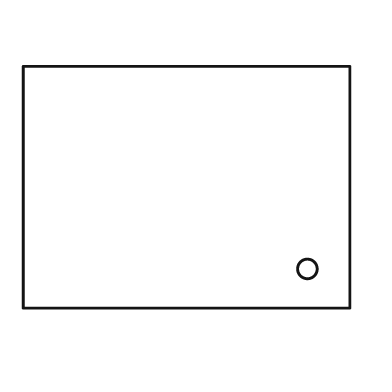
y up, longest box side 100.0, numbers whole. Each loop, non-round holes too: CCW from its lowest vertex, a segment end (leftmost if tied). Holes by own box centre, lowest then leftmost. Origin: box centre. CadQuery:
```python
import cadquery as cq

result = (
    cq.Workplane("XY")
    .moveTo(-50.0, -37.0)
    .lineTo(50.0, -37.0)
    .lineTo(50.0, 37.0)
    .lineTo(-50.0, 37.0)
    .close()
    .moveTo(37.0, -25.0)
    .circle(3.0)
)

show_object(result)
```